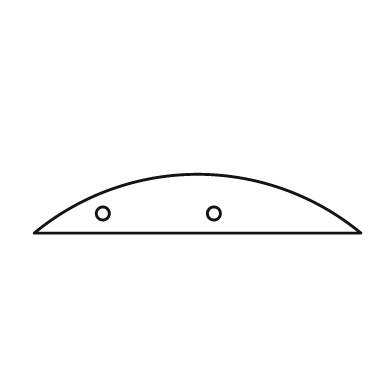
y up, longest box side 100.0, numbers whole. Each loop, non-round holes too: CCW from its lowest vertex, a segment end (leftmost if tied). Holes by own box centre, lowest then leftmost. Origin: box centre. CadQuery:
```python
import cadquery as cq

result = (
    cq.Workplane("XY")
    .moveTo(-50.0, -9.0)
    .lineTo(50.0, -9.0)
    .threePointArc((0.0, 9.0), (-50.0, -9.0))
    .close()
    .moveTo(-29.0, -3.0)
    .circle(2.0)
    .moveTo(5.0, -3.0)
    .circle(2.0)
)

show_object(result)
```